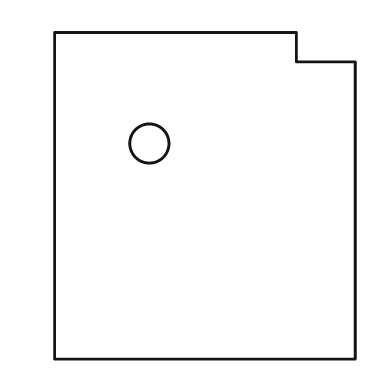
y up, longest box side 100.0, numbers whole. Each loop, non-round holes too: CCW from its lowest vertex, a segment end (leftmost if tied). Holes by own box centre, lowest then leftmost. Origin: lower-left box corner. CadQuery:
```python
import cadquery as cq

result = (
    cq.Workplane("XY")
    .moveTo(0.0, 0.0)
    .lineTo(92.0, 0.0)
    .lineTo(92.0, 91.0)
    .lineTo(74.0, 91.0)
    .lineTo(74.0, 100.0)
    .lineTo(0.0, 100.0)
    .close()
    .moveTo(29.0, 66.0)
    .circle(6.0)
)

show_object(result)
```